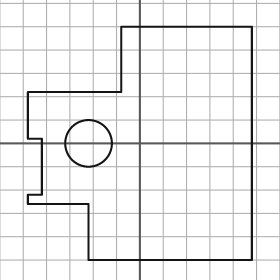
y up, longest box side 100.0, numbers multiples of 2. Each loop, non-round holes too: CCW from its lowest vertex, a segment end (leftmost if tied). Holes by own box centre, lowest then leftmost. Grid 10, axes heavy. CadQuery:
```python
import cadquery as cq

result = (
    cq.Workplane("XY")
    .moveTo(-22.0, -50.0)
    .lineTo(48.0, -50.0)
    .lineTo(48.0, 50.0)
    .lineTo(-8.0, 50.0)
    .lineTo(-8.0, 22.0)
    .lineTo(-48.0, 22.0)
    .lineTo(-48.0, 2.0)
    .lineTo(-42.0, 2.0)
    .lineTo(-42.0, -22.0)
    .lineTo(-48.0, -22.0)
    .lineTo(-48.0, -26.0)
    .lineTo(-22.0, -26.0)
    .close()
    .moveTo(-22.0, 0.0)
    .circle(10.0)
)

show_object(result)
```